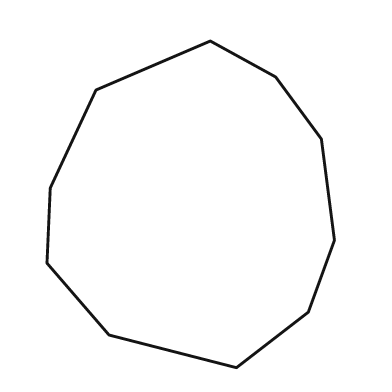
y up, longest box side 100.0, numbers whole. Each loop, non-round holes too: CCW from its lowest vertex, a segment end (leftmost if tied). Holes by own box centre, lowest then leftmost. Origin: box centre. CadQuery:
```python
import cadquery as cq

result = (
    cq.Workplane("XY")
    .moveTo(14.0, -50.0)
    .lineTo(36.0, -33.0)
    .lineTo(44.0, -11.0)
    .lineTo(40.0, 20.0)
    .lineTo(26.0, 39.0)
    .lineTo(6.0, 50.0)
    .lineTo(-29.0, 35.0)
    .lineTo(-43.0, 5.0)
    .lineTo(-44.0, -18.0)
    .lineTo(-25.0, -40.0)
    .close()
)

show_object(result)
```